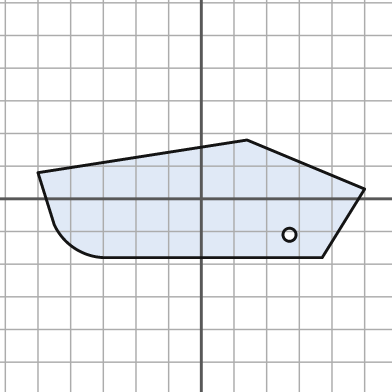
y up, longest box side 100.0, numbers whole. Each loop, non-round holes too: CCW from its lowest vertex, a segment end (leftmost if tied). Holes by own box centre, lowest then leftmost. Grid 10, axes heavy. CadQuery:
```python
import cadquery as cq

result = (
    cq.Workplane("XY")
    .moveTo(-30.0, -18.0)
    .lineTo(37.0, -18.0)
    .lineTo(50.0, 3.0)
    .lineTo(14.0, 18.0)
    .lineTo(-50.0, 8.0)
    .lineTo(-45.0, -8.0)
    .threePointArc((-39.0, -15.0), (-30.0, -18.0))
    .close()
    .moveTo(27.0, -11.0)
    .circle(2.0)
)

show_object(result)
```